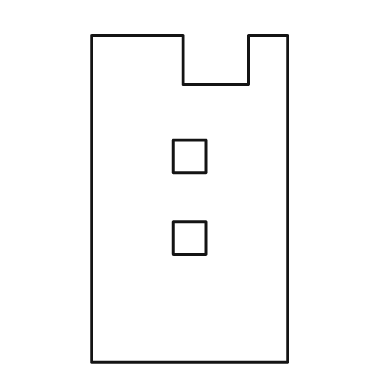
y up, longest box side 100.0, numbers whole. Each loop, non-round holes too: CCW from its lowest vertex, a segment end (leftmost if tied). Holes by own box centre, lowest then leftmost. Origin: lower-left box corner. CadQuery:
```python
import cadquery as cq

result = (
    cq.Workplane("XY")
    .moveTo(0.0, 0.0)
    .lineTo(60.0, 0.0)
    .lineTo(60.0, 100.0)
    .lineTo(48.0, 100.0)
    .lineTo(48.0, 85.0)
    .lineTo(28.0, 85.0)
    .lineTo(28.0, 100.0)
    .lineTo(0.0, 100.0)
    .close()
    .moveTo(25.0, 33.0)
    .lineTo(35.0, 33.0)
    .lineTo(35.0, 43.0)
    .lineTo(25.0, 43.0)
    .close()
    .moveTo(25.0, 58.0)
    .lineTo(35.0, 58.0)
    .lineTo(35.0, 68.0)
    .lineTo(25.0, 68.0)
    .close()
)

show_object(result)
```